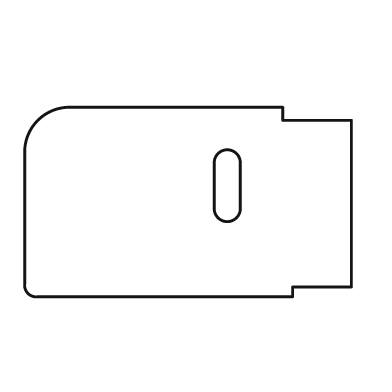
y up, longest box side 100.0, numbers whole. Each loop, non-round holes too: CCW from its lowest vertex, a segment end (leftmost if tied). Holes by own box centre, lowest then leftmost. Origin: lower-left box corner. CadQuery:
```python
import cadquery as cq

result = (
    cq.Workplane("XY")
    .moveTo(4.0, 0.0)
    .lineTo(82.0, 0.0)
    .lineTo(82.0, 3.0)
    .lineTo(100.0, 3.0)
    .lineTo(100.0, 54.0)
    .lineTo(79.0, 54.0)
    .lineTo(79.0, 58.0)
    .lineTo(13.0, 58.0)
    .threePointArc((4.0, 54.0), (0.0, 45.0))
    .lineTo(0.0, 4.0)
    .threePointArc((1.0, 1.0), (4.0, 0.0))
    .close()
    .moveTo(58.0, 27.0)
    .threePointArc((62.0, 23.0), (66.0, 27.0))
    .lineTo(66.0, 41.0)
    .threePointArc((62.0, 45.0), (58.0, 41.0))
    .close()
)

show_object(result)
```